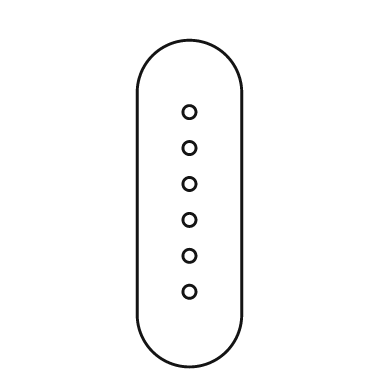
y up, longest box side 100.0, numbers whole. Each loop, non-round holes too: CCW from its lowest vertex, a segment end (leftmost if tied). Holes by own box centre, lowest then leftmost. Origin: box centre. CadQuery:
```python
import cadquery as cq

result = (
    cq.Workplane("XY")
    .moveTo(-16.0, -34.0)
    .threePointArc((0.0, -50.0), (16.0, -34.0))
    .lineTo(16.0, 34.0)
    .threePointArc((0.0, 50.0), (-16.0, 34.0))
    .close()
    .moveTo(0.0, -27.0)
    .circle(2.0)
    .moveTo(0.0, -16.0)
    .circle(2.0)
    .moveTo(0.0, -5.0)
    .circle(2.0)
    .moveTo(0.0, 6.0)
    .circle(2.0)
    .moveTo(0.0, 17.0)
    .circle(2.0)
    .moveTo(0.0, 28.0)
    .circle(2.0)
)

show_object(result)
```